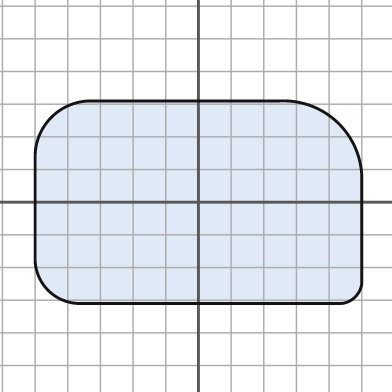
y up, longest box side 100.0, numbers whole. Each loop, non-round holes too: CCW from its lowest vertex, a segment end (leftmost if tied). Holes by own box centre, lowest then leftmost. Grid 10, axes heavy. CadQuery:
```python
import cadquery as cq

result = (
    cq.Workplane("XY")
    .moveTo(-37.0, -31.0)
    .lineTo(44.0, -31.0)
    .threePointArc((48.0, -29.0), (50.0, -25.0))
    .lineTo(50.0, 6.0)
    .threePointArc((43.0, 24.0), (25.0, 31.0))
    .lineTo(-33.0, 31.0)
    .threePointArc((-45.0, 26.0), (-50.0, 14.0))
    .lineTo(-50.0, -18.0)
    .threePointArc((-46.0, -27.0), (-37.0, -31.0))
    .close()
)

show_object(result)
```